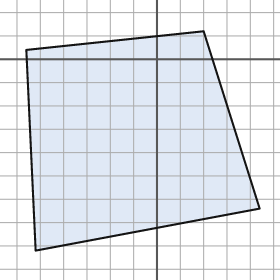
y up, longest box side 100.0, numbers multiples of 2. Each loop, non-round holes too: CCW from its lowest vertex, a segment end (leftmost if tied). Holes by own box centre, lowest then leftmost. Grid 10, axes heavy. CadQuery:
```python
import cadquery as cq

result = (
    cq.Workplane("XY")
    .moveTo(-52.0, -82.0)
    .lineTo(44.0, -64.0)
    .lineTo(20.0, 12.0)
    .lineTo(-56.0, 4.0)
    .close()
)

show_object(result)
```